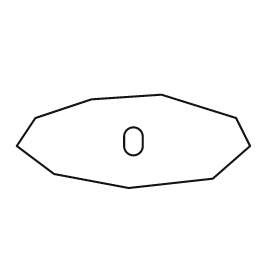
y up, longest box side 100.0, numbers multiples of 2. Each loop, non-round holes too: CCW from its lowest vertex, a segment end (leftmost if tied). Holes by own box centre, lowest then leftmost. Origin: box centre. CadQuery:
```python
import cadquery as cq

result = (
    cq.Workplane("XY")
    .moveTo(-2.0, -20.0)
    .lineTo(34.0, -16.0)
    .lineTo(50.0, -2.0)
    .lineTo(44.0, 10.0)
    .lineTo(12.0, 20.0)
    .lineTo(-18.0, 18.0)
    .lineTo(-42.0, 10.0)
    .lineTo(-50.0, -2.0)
    .lineTo(-34.0, -14.0)
    .close()
    .moveTo(-4.0, -2.0)
    .threePointArc((0.0, -6.0), (4.0, -2.0))
    .lineTo(4.0, 2.0)
    .threePointArc((0.0, 6.0), (-4.0, 2.0))
    .close()
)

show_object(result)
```